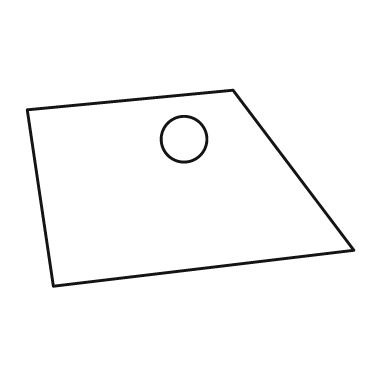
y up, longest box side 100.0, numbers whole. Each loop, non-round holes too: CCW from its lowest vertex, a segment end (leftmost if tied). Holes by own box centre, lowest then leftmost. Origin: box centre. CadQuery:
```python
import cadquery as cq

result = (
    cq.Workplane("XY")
    .moveTo(-42.0, -30.0)
    .lineTo(50.0, -19.0)
    .lineTo(13.0, 30.0)
    .lineTo(-50.0, 24.0)
    .close()
    .moveTo(-2.0, 15.0)
    .circle(7.0)
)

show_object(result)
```